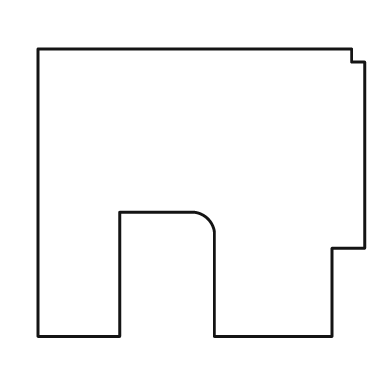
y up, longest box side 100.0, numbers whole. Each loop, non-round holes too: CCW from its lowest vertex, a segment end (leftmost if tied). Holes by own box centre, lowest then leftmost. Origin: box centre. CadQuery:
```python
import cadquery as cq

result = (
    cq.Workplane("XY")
    .moveTo(-50.0, -44.0)
    .lineTo(-25.0, -44.0)
    .lineTo(-25.0, -6.0)
    .lineTo(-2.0, -6.0)
    .threePointArc((2.0, -8.0), (4.0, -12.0))
    .lineTo(4.0, -44.0)
    .lineTo(40.0, -44.0)
    .lineTo(40.0, -17.0)
    .lineTo(50.0, -17.0)
    .lineTo(50.0, 40.0)
    .lineTo(46.0, 40.0)
    .lineTo(46.0, 44.0)
    .lineTo(-50.0, 44.0)
    .close()
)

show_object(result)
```